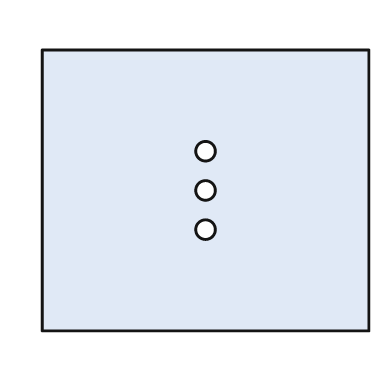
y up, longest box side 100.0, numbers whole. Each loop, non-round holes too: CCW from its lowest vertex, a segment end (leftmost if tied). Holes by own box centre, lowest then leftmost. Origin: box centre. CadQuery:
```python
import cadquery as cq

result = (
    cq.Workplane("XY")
    .moveTo(-50.0, -43.0)
    .lineTo(50.0, -43.0)
    .lineTo(50.0, 43.0)
    .lineTo(-50.0, 43.0)
    .close()
    .moveTo(0.0, -12.0)
    .circle(3.0)
    .moveTo(0.0, 0.0)
    .circle(3.0)
    .moveTo(0.0, 12.0)
    .circle(3.0)
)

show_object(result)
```